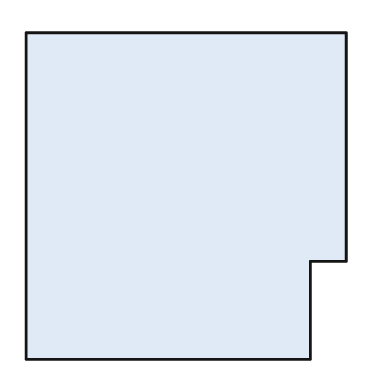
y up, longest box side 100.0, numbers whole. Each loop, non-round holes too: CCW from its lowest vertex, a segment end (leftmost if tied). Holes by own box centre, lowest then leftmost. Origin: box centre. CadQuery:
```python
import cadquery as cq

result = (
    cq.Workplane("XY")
    .moveTo(-49.0, -50.0)
    .lineTo(38.0, -50.0)
    .lineTo(38.0, -20.0)
    .lineTo(49.0, -20.0)
    .lineTo(49.0, 50.0)
    .lineTo(-49.0, 50.0)
    .close()
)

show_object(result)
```